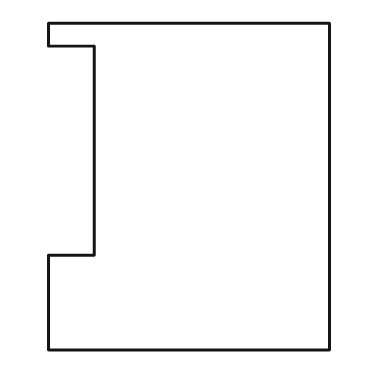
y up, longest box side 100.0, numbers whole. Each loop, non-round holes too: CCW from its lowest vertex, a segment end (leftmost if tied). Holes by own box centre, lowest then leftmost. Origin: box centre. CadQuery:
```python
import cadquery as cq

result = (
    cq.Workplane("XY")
    .moveTo(-43.0, -50.0)
    .lineTo(43.0, -50.0)
    .lineTo(43.0, 50.0)
    .lineTo(-43.0, 50.0)
    .lineTo(-43.0, 43.0)
    .lineTo(-29.0, 43.0)
    .lineTo(-29.0, -21.0)
    .lineTo(-43.0, -21.0)
    .close()
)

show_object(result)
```